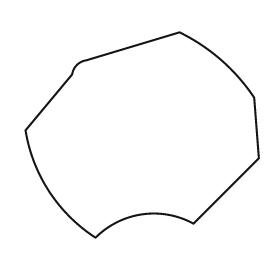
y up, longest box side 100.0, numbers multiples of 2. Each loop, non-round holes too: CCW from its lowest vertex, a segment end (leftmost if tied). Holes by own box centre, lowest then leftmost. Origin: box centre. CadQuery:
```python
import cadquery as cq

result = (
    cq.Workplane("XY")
    .moveTo(-20.0, -44.0)
    .threePointArc((0.0, -34.0), (22.0, -38.0))
    .lineTo(50.0, -10.0)
    .lineTo(48.0, 16.0)
    .threePointArc((34.0, 32.0), (16.0, 44.0))
    .lineTo(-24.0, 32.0)
    .threePointArc((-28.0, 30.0), (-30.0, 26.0))
    .lineTo(-50.0, 2.0)
    .threePointArc((-40.0, -24.0), (-20.0, -44.0))
    .close()
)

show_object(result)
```